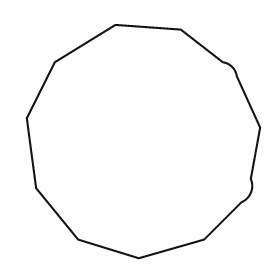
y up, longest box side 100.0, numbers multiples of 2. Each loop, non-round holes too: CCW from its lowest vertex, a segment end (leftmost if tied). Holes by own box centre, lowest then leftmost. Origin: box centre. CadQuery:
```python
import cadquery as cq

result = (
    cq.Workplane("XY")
    .moveTo(-2.0, -50.0)
    .lineTo(26.0, -42.0)
    .lineTo(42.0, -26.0)
    .threePointArc((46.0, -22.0), (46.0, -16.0))
    .lineTo(50.0, 6.0)
    .lineTo(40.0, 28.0)
    .threePointArc((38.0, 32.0), (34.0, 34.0))
    .lineTo(16.0, 48.0)
    .lineTo(-12.0, 50.0)
    .lineTo(-38.0, 34.0)
    .lineTo(-50.0, 10.0)
    .lineTo(-46.0, -20.0)
    .lineTo(-28.0, -42.0)
    .close()
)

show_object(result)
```